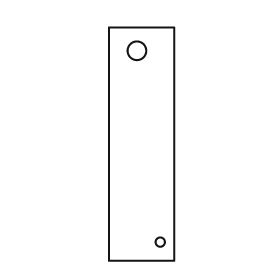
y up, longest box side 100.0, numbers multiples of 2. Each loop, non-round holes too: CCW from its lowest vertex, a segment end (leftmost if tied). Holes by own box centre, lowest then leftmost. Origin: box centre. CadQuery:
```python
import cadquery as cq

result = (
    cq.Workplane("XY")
    .moveTo(-14.0, -50.0)
    .lineTo(14.0, -50.0)
    .lineTo(14.0, 50.0)
    .lineTo(-14.0, 50.0)
    .close()
    .moveTo(8.0, -42.0)
    .circle(2.0)
    .moveTo(-2.0, 40.0)
    .circle(4.0)
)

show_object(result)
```